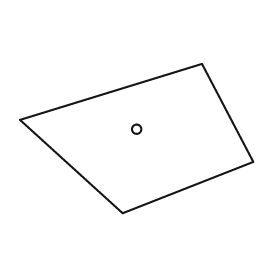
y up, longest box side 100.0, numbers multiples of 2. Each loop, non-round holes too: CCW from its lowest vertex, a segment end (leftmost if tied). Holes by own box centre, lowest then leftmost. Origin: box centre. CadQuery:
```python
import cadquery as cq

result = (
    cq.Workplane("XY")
    .moveTo(-6.0, -32.0)
    .lineTo(50.0, -10.0)
    .lineTo(28.0, 32.0)
    .lineTo(-50.0, 8.0)
    .close()
    .moveTo(0.0, 4.0)
    .circle(2.0)
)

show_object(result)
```